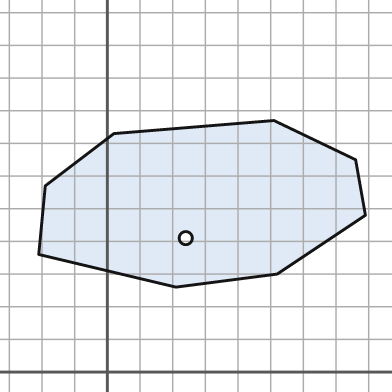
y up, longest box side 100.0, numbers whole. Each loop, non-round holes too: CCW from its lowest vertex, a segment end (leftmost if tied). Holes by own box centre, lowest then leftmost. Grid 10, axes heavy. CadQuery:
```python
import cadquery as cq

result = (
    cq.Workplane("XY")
    .moveTo(21.0, 26.0)
    .lineTo(52.0, 30.0)
    .lineTo(79.0, 48.0)
    .lineTo(76.0, 65.0)
    .lineTo(51.0, 77.0)
    .lineTo(2.0, 73.0)
    .lineTo(-19.0, 57.0)
    .lineTo(-21.0, 36.0)
    .close()
    .moveTo(24.0, 41.0)
    .circle(2.0)
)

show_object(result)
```